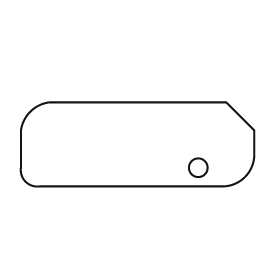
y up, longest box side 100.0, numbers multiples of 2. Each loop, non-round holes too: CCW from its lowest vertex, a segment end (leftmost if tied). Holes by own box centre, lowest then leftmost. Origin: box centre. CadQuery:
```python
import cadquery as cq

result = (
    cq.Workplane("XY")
    .moveTo(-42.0, -18.0)
    .lineTo(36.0, -18.0)
    .threePointArc((46.0, -14.0), (50.0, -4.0))
    .lineTo(50.0, 6.0)
    .lineTo(38.0, 18.0)
    .lineTo(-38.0, 18.0)
    .threePointArc((-46.0, 14.0), (-50.0, 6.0))
    .lineTo(-50.0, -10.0)
    .threePointArc((-48.0, -16.0), (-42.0, -18.0))
    .close()
    .moveTo(26.0, -10.0)
    .circle(4.0)
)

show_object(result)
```